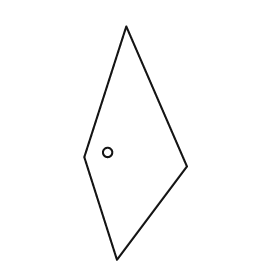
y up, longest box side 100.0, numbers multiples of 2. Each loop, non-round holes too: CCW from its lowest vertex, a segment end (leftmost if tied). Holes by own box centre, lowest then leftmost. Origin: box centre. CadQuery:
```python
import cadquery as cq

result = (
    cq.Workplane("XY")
    .moveTo(-8.0, -50.0)
    .lineTo(22.0, -10.0)
    .lineTo(-4.0, 50.0)
    .lineTo(-22.0, -6.0)
    .close()
    .moveTo(-12.0, -4.0)
    .circle(2.0)
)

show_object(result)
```